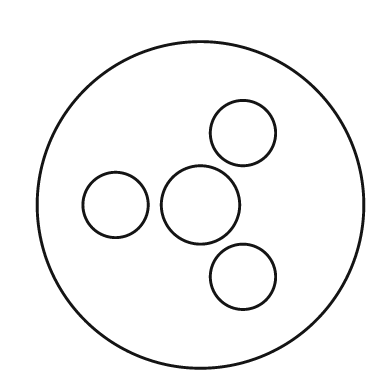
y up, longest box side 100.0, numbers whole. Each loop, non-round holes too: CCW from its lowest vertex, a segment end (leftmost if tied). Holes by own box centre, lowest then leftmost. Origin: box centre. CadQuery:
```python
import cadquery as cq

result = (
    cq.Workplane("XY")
    .moveTo(0.0, 0.0)
    .circle(50.0)
    .moveTo(13.0, -22.0)
    .circle(10.0)
    .moveTo(-26.0, 0.0)
    .circle(10.0)
    .moveTo(0.0, 0.0)
    .circle(12.0)
    .moveTo(13.0, 22.0)
    .circle(10.0)
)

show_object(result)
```